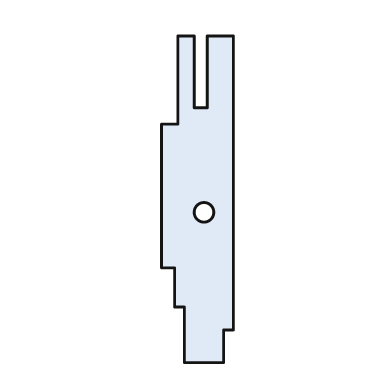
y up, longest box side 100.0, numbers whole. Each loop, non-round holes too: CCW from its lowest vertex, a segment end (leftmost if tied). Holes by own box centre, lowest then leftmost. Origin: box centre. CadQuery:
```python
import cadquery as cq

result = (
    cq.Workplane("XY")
    .moveTo(-4.0, -50.0)
    .lineTo(8.0, -50.0)
    .lineTo(8.0, -40.0)
    .lineTo(11.0, -40.0)
    .lineTo(11.0, 50.0)
    .lineTo(3.0, 50.0)
    .lineTo(3.0, 28.0)
    .lineTo(-1.0, 28.0)
    .lineTo(-1.0, 50.0)
    .lineTo(-6.0, 50.0)
    .lineTo(-6.0, 23.0)
    .lineTo(-11.0, 23.0)
    .lineTo(-11.0, -21.0)
    .lineTo(-7.0, -21.0)
    .lineTo(-7.0, -33.0)
    .lineTo(-4.0, -33.0)
    .close()
    .moveTo(2.0, -4.0)
    .circle(3.0)
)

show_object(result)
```